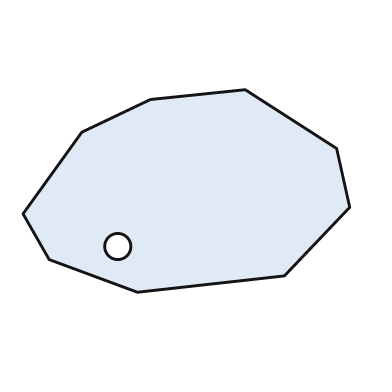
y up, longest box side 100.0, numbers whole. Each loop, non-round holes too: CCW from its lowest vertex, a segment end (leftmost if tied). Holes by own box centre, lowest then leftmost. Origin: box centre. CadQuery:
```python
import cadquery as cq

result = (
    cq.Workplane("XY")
    .moveTo(-15.0, -31.0)
    .lineTo(30.0, -26.0)
    .lineTo(50.0, -5.0)
    .lineTo(46.0, 13.0)
    .lineTo(18.0, 31.0)
    .lineTo(-11.0, 28.0)
    .lineTo(-32.0, 18.0)
    .lineTo(-50.0, -7.0)
    .lineTo(-42.0, -21.0)
    .close()
    .moveTo(-21.0, -17.0)
    .circle(4.0)
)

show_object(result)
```